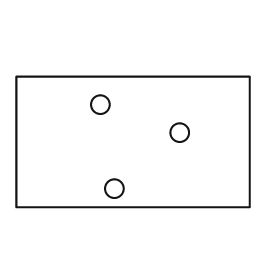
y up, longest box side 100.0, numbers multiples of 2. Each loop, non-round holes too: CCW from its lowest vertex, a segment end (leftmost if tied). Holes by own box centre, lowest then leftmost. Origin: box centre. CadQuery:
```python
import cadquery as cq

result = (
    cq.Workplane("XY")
    .moveTo(-50.0, -28.0)
    .lineTo(50.0, -28.0)
    .lineTo(50.0, 28.0)
    .lineTo(-50.0, 28.0)
    .close()
    .moveTo(-8.0, -20.0)
    .circle(4.0)
    .moveTo(20.0, 4.0)
    .circle(4.0)
    .moveTo(-14.0, 16.0)
    .circle(4.0)
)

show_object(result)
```